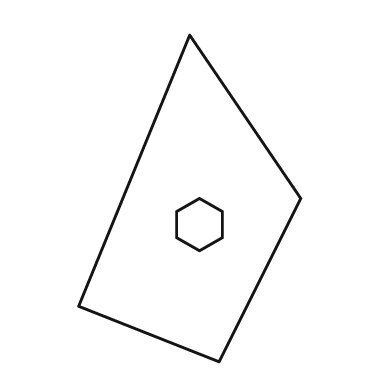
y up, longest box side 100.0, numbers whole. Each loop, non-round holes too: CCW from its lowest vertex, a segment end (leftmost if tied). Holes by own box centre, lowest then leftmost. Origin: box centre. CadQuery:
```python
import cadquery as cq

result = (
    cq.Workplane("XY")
    .moveTo(9.0, -50.0)
    .lineTo(34.0, 0.0)
    .lineTo(0.0, 50.0)
    .lineTo(-34.0, -33.0)
    .close()
    .moveTo(3.0, -16.0)
    .lineTo(10.0, -12.0)
    .lineTo(10.0, -4.0)
    .lineTo(3.0, 0.0)
    .lineTo(-4.0, -4.0)
    .lineTo(-4.0, -12.0)
    .close()
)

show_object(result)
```